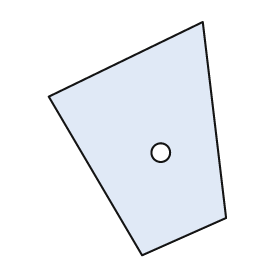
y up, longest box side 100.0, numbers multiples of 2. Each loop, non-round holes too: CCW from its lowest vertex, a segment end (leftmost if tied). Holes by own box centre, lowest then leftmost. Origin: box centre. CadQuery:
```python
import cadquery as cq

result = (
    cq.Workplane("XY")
    .moveTo(2.0, -50.0)
    .lineTo(38.0, -34.0)
    .lineTo(28.0, 50.0)
    .lineTo(-38.0, 18.0)
    .close()
    .moveTo(10.0, -6.0)
    .circle(4.0)
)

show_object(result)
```